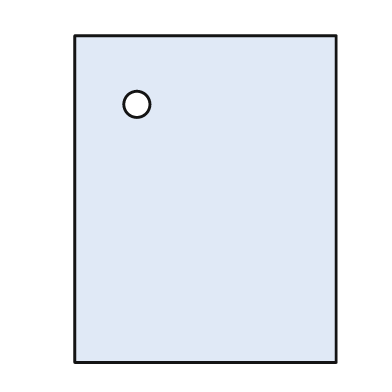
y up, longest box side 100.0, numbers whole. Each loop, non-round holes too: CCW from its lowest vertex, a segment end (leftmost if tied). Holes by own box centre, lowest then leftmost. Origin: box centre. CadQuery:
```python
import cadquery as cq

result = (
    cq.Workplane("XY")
    .moveTo(-40.0, -50.0)
    .lineTo(40.0, -50.0)
    .lineTo(40.0, 50.0)
    .lineTo(-40.0, 50.0)
    .close()
    .moveTo(-21.0, 29.0)
    .circle(4.0)
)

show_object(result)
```